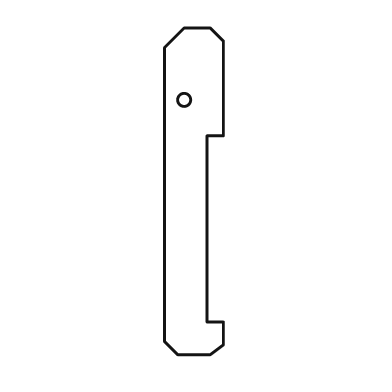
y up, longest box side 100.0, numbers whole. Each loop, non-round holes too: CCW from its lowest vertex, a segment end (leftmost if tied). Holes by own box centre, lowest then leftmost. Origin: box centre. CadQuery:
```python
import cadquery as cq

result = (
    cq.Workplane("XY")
    .moveTo(-5.0, -50.0)
    .lineTo(5.0, -50.0)
    .lineTo(9.0, -47.0)
    .lineTo(9.0, -40.0)
    .lineTo(4.0, -40.0)
    .lineTo(4.0, 17.0)
    .lineTo(9.0, 17.0)
    .lineTo(9.0, 46.0)
    .lineTo(5.0, 50.0)
    .lineTo(-3.0, 50.0)
    .lineTo(-9.0, 44.0)
    .lineTo(-9.0, -46.0)
    .close()
    .moveTo(-3.0, 28.0)
    .circle(2.0)
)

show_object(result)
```